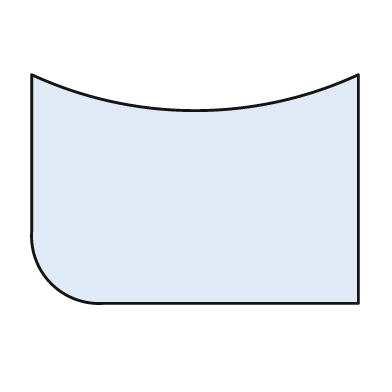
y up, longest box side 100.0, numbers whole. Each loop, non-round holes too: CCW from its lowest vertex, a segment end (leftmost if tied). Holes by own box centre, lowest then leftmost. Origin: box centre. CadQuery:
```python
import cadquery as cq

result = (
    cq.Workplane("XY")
    .moveTo(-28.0, -35.0)
    .lineTo(50.0, -35.0)
    .lineTo(50.0, 35.0)
    .threePointArc((0.0, 24.0), (-50.0, 35.0))
    .lineTo(-50.0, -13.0)
    .threePointArc((-44.0, -29.0), (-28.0, -35.0))
    .close()
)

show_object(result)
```